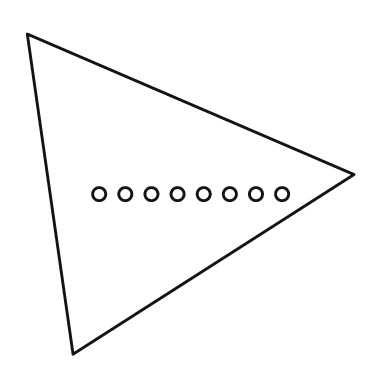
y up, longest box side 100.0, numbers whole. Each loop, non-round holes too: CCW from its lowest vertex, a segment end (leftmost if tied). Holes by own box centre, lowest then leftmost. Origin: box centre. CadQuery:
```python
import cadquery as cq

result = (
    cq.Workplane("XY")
    .moveTo(-36.0, -49.0)
    .lineTo(50.0, 6.0)
    .lineTo(-50.0, 49.0)
    .close()
    .moveTo(-28.0, 0.0)
    .circle(2.0)
    .moveTo(-20.0, 0.0)
    .circle(2.0)
    .moveTo(-12.0, 0.0)
    .circle(2.0)
    .moveTo(-4.0, 0.0)
    .circle(2.0)
    .moveTo(4.0, 0.0)
    .circle(2.0)
    .moveTo(12.0, 0.0)
    .circle(2.0)
    .moveTo(20.0, 0.0)
    .circle(2.0)
    .moveTo(28.0, 0.0)
    .circle(2.0)
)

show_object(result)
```